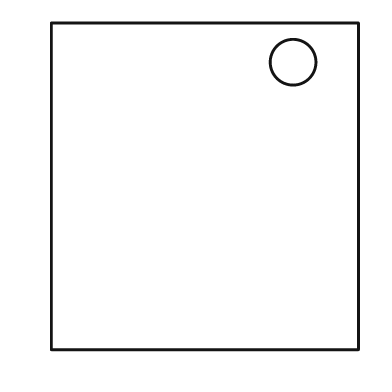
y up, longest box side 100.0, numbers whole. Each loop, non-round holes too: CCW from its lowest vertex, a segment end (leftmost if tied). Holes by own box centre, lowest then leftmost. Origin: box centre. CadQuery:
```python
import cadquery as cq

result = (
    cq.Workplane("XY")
    .moveTo(-47.0, -50.0)
    .lineTo(47.0, -50.0)
    .lineTo(47.0, 50.0)
    .lineTo(-47.0, 50.0)
    .close()
    .moveTo(27.0, 38.0)
    .circle(7.0)
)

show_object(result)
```